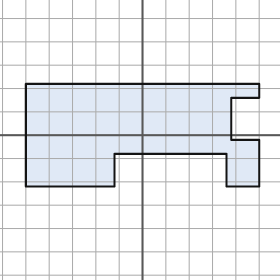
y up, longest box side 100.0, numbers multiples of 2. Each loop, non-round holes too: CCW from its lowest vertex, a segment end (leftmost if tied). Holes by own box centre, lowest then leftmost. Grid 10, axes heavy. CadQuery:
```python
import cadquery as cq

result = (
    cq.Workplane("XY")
    .moveTo(-50.0, -22.0)
    .lineTo(-12.0, -22.0)
    .lineTo(-12.0, -8.0)
    .lineTo(36.0, -8.0)
    .lineTo(36.0, -22.0)
    .lineTo(50.0, -22.0)
    .lineTo(50.0, -2.0)
    .lineTo(38.0, -2.0)
    .lineTo(38.0, 16.0)
    .lineTo(50.0, 16.0)
    .lineTo(50.0, 22.0)
    .lineTo(-50.0, 22.0)
    .close()
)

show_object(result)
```